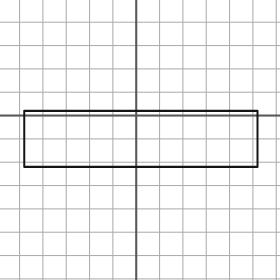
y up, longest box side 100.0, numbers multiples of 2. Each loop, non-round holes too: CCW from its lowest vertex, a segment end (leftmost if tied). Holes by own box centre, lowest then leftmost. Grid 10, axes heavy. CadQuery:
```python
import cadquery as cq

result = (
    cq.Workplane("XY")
    .moveTo(-48.0, -22.0)
    .lineTo(52.0, -22.0)
    .lineTo(52.0, 2.0)
    .lineTo(-48.0, 2.0)
    .close()
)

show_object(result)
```